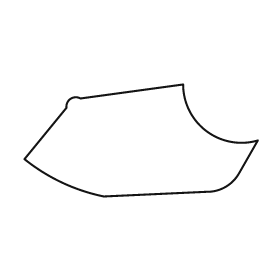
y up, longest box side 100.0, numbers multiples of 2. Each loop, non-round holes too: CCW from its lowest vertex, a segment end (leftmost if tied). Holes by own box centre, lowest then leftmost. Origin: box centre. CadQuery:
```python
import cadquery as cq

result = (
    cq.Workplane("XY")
    .moveTo(-16.0, -24.0)
    .lineTo(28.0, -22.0)
    .threePointArc((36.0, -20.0), (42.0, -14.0))
    .lineTo(50.0, 0.0)
    .threePointArc((28.0, 4.0), (18.0, 24.0))
    .lineTo(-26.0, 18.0)
    .threePointArc((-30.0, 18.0), (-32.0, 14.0))
    .lineTo(-50.0, -8.0)
    .threePointArc((-34.0, -18.0), (-16.0, -24.0))
    .close()
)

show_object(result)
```